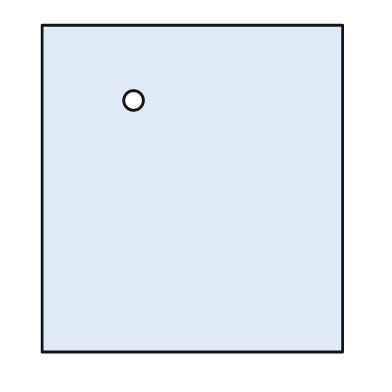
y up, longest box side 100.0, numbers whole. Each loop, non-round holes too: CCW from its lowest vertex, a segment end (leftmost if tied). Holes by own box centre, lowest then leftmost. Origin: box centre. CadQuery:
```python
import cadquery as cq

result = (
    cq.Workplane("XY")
    .moveTo(-46.0, -50.0)
    .lineTo(46.0, -50.0)
    .lineTo(46.0, 50.0)
    .lineTo(-46.0, 50.0)
    .close()
    .moveTo(-18.0, 27.0)
    .circle(3.0)
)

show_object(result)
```